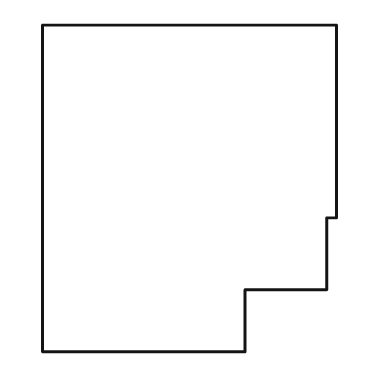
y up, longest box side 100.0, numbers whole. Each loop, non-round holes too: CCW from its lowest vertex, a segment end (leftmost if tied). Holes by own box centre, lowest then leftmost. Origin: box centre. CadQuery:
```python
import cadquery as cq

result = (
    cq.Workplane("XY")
    .moveTo(-45.0, -50.0)
    .lineTo(17.0, -50.0)
    .lineTo(17.0, -31.0)
    .lineTo(42.0, -31.0)
    .lineTo(42.0, -9.0)
    .lineTo(45.0, -9.0)
    .lineTo(45.0, 50.0)
    .lineTo(-45.0, 50.0)
    .close()
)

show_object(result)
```